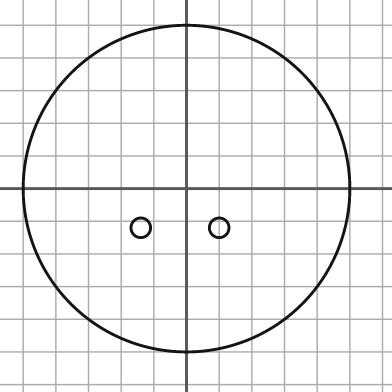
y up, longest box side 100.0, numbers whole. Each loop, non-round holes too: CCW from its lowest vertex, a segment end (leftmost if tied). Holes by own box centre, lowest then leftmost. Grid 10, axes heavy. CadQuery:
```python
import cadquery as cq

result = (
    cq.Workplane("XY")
    .moveTo(0.0, 0.0)
    .circle(50.0)
    .moveTo(-14.0, -12.0)
    .circle(3.0)
    .moveTo(10.0, -12.0)
    .circle(3.0)
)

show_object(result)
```